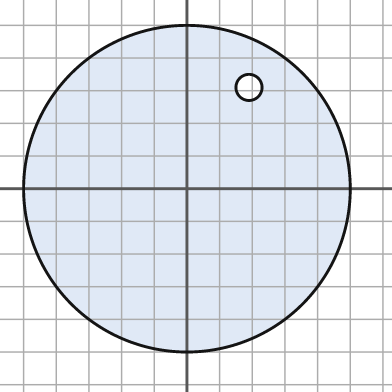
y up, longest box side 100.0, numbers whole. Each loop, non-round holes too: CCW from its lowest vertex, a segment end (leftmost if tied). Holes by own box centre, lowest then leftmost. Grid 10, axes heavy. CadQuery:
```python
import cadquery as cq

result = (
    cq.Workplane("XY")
    .moveTo(0.0, 0.0)
    .circle(50.0)
    .moveTo(19.0, 31.0)
    .circle(4.0)
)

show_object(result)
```